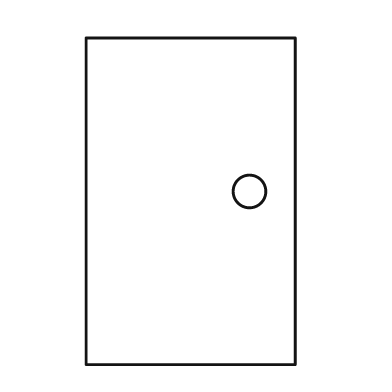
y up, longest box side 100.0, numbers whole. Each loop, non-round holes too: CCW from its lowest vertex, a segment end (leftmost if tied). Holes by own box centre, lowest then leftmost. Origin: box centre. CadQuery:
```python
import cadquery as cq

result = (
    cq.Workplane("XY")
    .moveTo(-32.0, -50.0)
    .lineTo(32.0, -50.0)
    .lineTo(32.0, 50.0)
    .lineTo(-32.0, 50.0)
    .close()
    .moveTo(18.0, 3.0)
    .circle(5.0)
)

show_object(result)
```